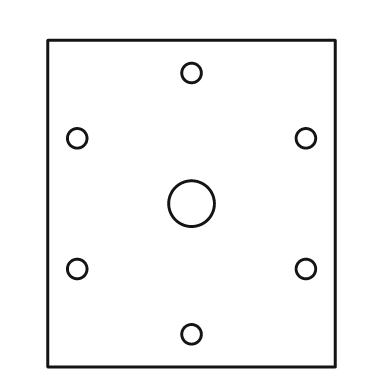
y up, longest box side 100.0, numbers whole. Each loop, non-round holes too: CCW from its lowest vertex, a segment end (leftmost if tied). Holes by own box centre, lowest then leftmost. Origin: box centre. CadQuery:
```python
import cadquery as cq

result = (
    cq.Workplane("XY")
    .moveTo(-44.0, -50.0)
    .lineTo(44.0, -50.0)
    .lineTo(44.0, 50.0)
    .lineTo(-44.0, 50.0)
    .close()
    .moveTo(0.0, -40.0)
    .circle(3.0)
    .moveTo(-35.0, -20.0)
    .circle(3.0)
    .moveTo(35.0, -20.0)
    .circle(3.0)
    .moveTo(0.0, 0.0)
    .circle(7.0)
    .moveTo(-35.0, 20.0)
    .circle(3.0)
    .moveTo(35.0, 20.0)
    .circle(3.0)
    .moveTo(0.0, 40.0)
    .circle(3.0)
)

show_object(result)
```